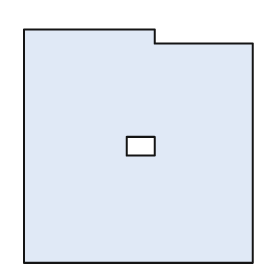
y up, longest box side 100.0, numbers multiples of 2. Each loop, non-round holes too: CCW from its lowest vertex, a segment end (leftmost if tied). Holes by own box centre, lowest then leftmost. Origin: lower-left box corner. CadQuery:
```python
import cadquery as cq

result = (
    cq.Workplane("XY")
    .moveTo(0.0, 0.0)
    .lineTo(98.0, 0.0)
    .lineTo(98.0, 94.0)
    .lineTo(56.0, 94.0)
    .lineTo(56.0, 100.0)
    .lineTo(0.0, 100.0)
    .close()
    .moveTo(44.0, 46.0)
    .lineTo(56.0, 46.0)
    .lineTo(56.0, 54.0)
    .lineTo(44.0, 54.0)
    .close()
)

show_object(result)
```